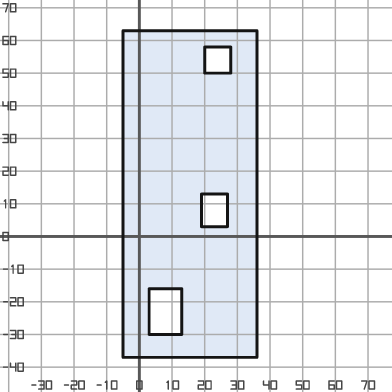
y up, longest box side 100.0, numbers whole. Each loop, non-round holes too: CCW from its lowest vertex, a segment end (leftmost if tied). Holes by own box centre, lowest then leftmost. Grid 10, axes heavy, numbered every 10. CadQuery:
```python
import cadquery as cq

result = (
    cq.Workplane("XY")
    .moveTo(-5.0, -37.0)
    .lineTo(36.0, -37.0)
    .lineTo(36.0, 63.0)
    .lineTo(-5.0, 63.0)
    .close()
    .moveTo(3.0, -30.0)
    .lineTo(13.0, -30.0)
    .lineTo(13.0, -16.0)
    .lineTo(3.0, -16.0)
    .close()
    .moveTo(19.0, 3.0)
    .lineTo(27.0, 3.0)
    .lineTo(27.0, 13.0)
    .lineTo(19.0, 13.0)
    .close()
    .moveTo(20.0, 50.0)
    .lineTo(28.0, 50.0)
    .lineTo(28.0, 58.0)
    .lineTo(20.0, 58.0)
    .close()
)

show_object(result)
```